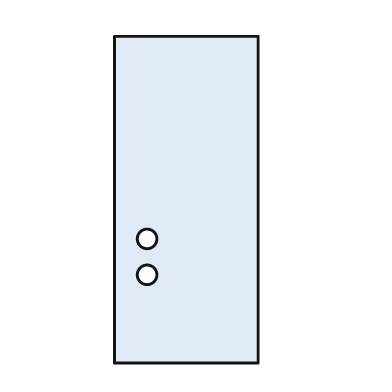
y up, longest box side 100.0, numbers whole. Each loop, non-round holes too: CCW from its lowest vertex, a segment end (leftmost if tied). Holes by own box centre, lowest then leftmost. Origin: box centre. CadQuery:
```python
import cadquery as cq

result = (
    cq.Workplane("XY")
    .moveTo(-22.0, -50.0)
    .lineTo(22.0, -50.0)
    .lineTo(22.0, 50.0)
    .lineTo(-22.0, 50.0)
    .close()
    .moveTo(-12.0, -23.0)
    .circle(3.0)
    .moveTo(-12.0, -12.0)
    .circle(3.0)
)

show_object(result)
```